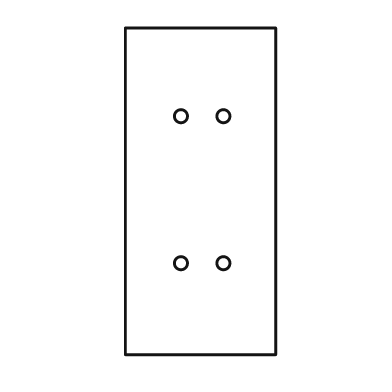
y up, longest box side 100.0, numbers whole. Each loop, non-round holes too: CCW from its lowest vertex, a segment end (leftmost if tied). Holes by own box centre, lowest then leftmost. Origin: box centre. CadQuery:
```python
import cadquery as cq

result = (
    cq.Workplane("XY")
    .moveTo(-23.0, -50.0)
    .lineTo(23.0, -50.0)
    .lineTo(23.0, 50.0)
    .lineTo(-23.0, 50.0)
    .close()
    .moveTo(-6.0, -22.0)
    .circle(2.0)
    .moveTo(7.0, -22.0)
    .circle(2.0)
    .moveTo(-6.0, 23.0)
    .circle(2.0)
    .moveTo(7.0, 23.0)
    .circle(2.0)
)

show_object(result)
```